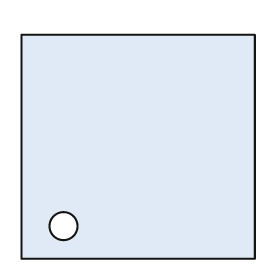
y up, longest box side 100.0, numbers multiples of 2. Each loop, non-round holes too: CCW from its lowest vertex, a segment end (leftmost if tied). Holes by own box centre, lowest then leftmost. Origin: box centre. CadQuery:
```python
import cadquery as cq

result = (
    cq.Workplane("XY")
    .moveTo(-50.0, -48.0)
    .lineTo(50.0, -48.0)
    .lineTo(50.0, 48.0)
    .lineTo(-50.0, 48.0)
    .close()
    .moveTo(-32.0, -34.0)
    .circle(6.0)
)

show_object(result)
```